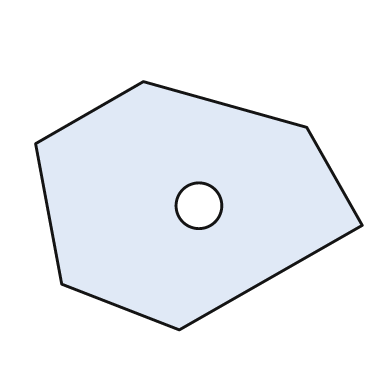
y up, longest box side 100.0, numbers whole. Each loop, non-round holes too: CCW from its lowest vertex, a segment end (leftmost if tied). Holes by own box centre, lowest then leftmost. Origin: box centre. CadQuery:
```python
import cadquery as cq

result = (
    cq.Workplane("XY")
    .moveTo(-6.0, -38.0)
    .lineTo(50.0, -6.0)
    .lineTo(33.0, 24.0)
    .lineTo(-17.0, 38.0)
    .lineTo(-50.0, 19.0)
    .lineTo(-42.0, -24.0)
    .close()
    .moveTo(0.0, 0.0)
    .circle(7.0)
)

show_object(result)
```